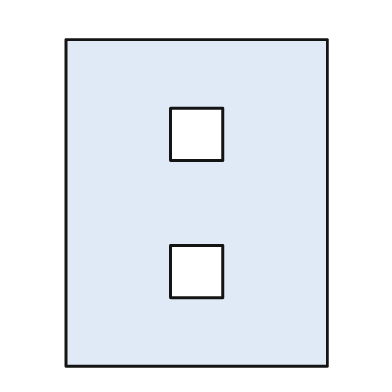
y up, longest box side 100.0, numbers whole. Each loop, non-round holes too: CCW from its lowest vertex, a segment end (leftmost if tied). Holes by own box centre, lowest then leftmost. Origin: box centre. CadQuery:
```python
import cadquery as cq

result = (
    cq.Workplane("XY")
    .moveTo(-40.0, -50.0)
    .lineTo(40.0, -50.0)
    .lineTo(40.0, 50.0)
    .lineTo(-40.0, 50.0)
    .close()
    .moveTo(-8.0, -29.0)
    .lineTo(8.0, -29.0)
    .lineTo(8.0, -13.0)
    .lineTo(-8.0, -13.0)
    .close()
    .moveTo(-8.0, 13.0)
    .lineTo(8.0, 13.0)
    .lineTo(8.0, 29.0)
    .lineTo(-8.0, 29.0)
    .close()
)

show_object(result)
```